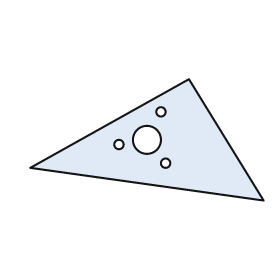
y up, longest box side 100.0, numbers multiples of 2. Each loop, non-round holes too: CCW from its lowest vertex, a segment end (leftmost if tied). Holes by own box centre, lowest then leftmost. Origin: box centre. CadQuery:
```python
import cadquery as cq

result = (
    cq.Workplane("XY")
    .moveTo(50.0, -26.0)
    .lineTo(18.0, 26.0)
    .lineTo(-50.0, -12.0)
    .close()
    .moveTo(8.0, -10.0)
    .circle(2.0)
    .moveTo(-12.0, -2.0)
    .circle(2.0)
    .moveTo(0.0, 0.0)
    .circle(6.0)
    .moveTo(6.0, 12.0)
    .circle(2.0)
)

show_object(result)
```